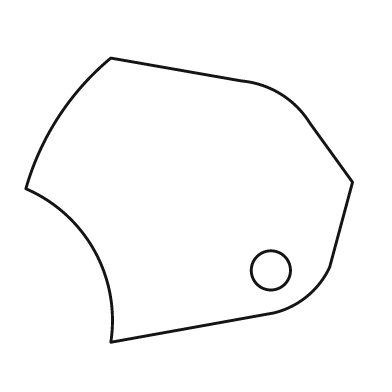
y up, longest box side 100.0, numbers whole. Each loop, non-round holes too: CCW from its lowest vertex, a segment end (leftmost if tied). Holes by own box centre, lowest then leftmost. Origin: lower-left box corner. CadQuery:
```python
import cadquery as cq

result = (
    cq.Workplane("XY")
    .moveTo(26.0, 0.0)
    .lineTo(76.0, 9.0)
    .threePointArc((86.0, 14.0), (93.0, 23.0))
    .lineTo(100.0, 49.0)
    .lineTo(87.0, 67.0)
    .threePointArc((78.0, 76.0), (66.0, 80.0))
    .lineTo(26.0, 87.0)
    .threePointArc((10.0, 69.0), (0.0, 47.0))
    .threePointArc((21.0, 28.0), (26.0, 0.0))
    .close()
    .moveTo(75.0, 22.0)
    .circle(6.0)
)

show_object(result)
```